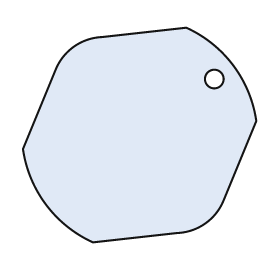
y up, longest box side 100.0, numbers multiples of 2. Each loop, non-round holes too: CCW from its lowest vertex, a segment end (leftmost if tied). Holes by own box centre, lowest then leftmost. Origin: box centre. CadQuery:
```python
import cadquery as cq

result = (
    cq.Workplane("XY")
    .moveTo(-20.0, -46.0)
    .lineTo(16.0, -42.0)
    .threePointArc((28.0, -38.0), (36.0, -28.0))
    .lineTo(50.0, 6.0)
    .threePointArc((40.0, 30.0), (20.0, 46.0))
    .lineTo(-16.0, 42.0)
    .threePointArc((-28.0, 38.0), (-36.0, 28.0))
    .lineTo(-50.0, -6.0)
    .threePointArc((-40.0, -30.0), (-20.0, -46.0))
    .close()
    .moveTo(32.0, 24.0)
    .circle(4.0)
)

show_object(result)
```